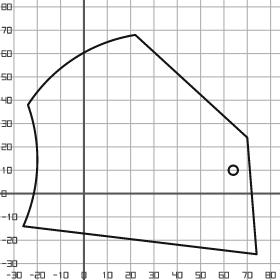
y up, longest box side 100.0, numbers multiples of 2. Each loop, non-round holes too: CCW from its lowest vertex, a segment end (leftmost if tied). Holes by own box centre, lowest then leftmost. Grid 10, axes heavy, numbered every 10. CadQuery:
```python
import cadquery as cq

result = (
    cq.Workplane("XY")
    .moveTo(74.0, -26.0)
    .lineTo(70.0, 24.0)
    .lineTo(22.0, 68.0)
    .threePointArc((-4.0, 58.0), (-24.0, 38.0))
    .threePointArc((-20.0, 12.0), (-26.0, -14.0))
    .close()
    .moveTo(64.0, 10.0)
    .circle(2.0)
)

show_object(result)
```